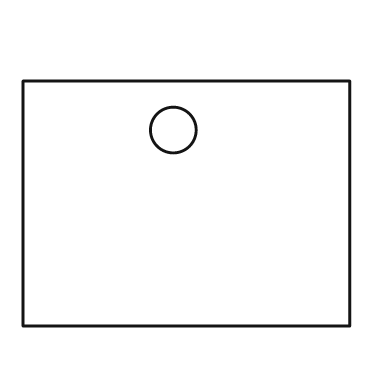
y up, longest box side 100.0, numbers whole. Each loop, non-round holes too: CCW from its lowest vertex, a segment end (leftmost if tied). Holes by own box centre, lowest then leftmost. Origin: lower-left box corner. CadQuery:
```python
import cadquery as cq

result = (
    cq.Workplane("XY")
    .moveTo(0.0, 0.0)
    .lineTo(100.0, 0.0)
    .lineTo(100.0, 75.0)
    .lineTo(0.0, 75.0)
    .close()
    .moveTo(46.0, 60.0)
    .circle(7.0)
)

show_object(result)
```